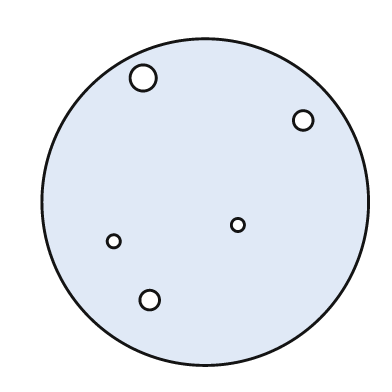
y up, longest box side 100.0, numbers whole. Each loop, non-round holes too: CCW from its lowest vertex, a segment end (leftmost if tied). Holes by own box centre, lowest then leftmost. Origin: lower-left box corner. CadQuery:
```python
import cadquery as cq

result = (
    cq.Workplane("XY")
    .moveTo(50.0, 50.0)
    .circle(50.0)
    .moveTo(33.0, 20.0)
    .circle(3.0)
    .moveTo(22.0, 38.0)
    .circle(2.0)
    .moveTo(60.0, 43.0)
    .circle(2.0)
    .moveTo(80.0, 75.0)
    .circle(3.0)
    .moveTo(31.0, 88.0)
    .circle(4.0)
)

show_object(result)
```